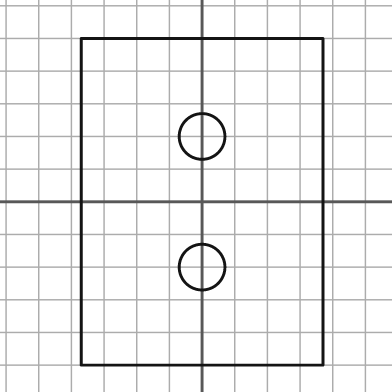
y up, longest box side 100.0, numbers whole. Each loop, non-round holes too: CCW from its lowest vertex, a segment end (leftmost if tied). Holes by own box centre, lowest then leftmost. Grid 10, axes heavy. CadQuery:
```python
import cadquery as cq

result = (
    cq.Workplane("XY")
    .moveTo(-37.0, -50.0)
    .lineTo(37.0, -50.0)
    .lineTo(37.0, 50.0)
    .lineTo(-37.0, 50.0)
    .close()
    .moveTo(0.0, -20.0)
    .circle(7.0)
    .moveTo(0.0, 20.0)
    .circle(7.0)
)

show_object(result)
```